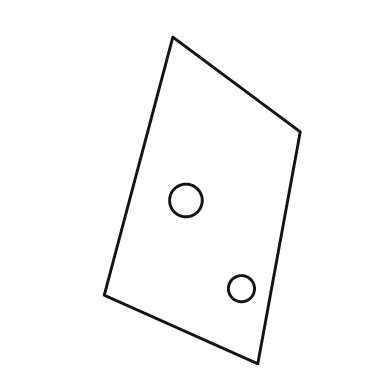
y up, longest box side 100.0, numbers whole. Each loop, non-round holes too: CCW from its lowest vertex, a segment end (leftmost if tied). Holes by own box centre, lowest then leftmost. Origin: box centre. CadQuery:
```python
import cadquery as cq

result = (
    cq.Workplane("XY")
    .moveTo(17.0, -50.0)
    .lineTo(30.0, 21.0)
    .lineTo(-9.0, 50.0)
    .lineTo(-30.0, -29.0)
    .close()
    .moveTo(12.0, -27.0)
    .circle(4.0)
    .moveTo(-5.0, 0.0)
    .circle(5.0)
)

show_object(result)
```